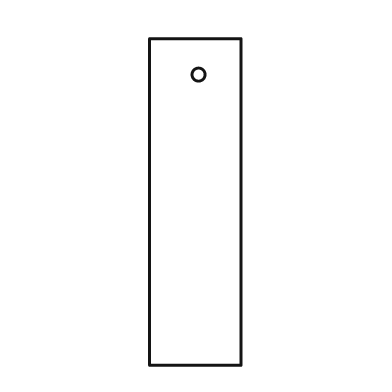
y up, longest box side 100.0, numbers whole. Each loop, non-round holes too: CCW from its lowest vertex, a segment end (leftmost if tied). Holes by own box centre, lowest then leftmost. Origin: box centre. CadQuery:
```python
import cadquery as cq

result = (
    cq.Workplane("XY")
    .moveTo(-14.0, -50.0)
    .lineTo(14.0, -50.0)
    .lineTo(14.0, 50.0)
    .lineTo(-14.0, 50.0)
    .close()
    .moveTo(1.0, 39.0)
    .circle(2.0)
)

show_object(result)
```